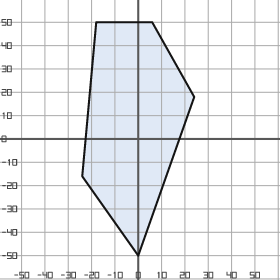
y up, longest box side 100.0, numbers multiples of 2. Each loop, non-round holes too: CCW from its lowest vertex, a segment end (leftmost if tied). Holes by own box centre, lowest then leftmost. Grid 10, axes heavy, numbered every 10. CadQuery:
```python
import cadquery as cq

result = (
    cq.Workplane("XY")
    .moveTo(0.0, -50.0)
    .lineTo(24.0, 18.0)
    .lineTo(6.0, 50.0)
    .lineTo(-18.0, 50.0)
    .lineTo(-24.0, -16.0)
    .close()
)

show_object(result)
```